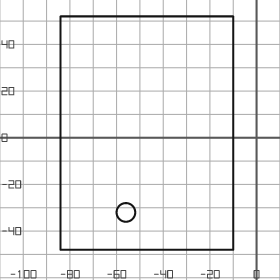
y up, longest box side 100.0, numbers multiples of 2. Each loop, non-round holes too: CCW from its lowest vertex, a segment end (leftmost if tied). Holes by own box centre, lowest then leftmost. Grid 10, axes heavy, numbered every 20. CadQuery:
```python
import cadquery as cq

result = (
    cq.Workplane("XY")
    .moveTo(-84.0, -48.0)
    .lineTo(-10.0, -48.0)
    .lineTo(-10.0, 52.0)
    .lineTo(-84.0, 52.0)
    .close()
    .moveTo(-56.0, -32.0)
    .circle(4.0)
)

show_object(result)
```